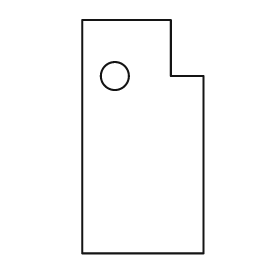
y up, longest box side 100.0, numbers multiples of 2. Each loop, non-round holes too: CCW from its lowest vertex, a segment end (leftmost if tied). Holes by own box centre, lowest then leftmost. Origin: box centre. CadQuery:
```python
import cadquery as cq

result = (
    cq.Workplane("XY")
    .moveTo(-26.0, -50.0)
    .lineTo(26.0, -50.0)
    .lineTo(26.0, 26.0)
    .lineTo(12.0, 26.0)
    .lineTo(12.0, 50.0)
    .lineTo(-26.0, 50.0)
    .close()
    .moveTo(-12.0, 26.0)
    .circle(6.0)
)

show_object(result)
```